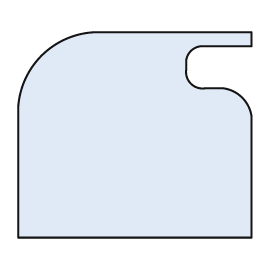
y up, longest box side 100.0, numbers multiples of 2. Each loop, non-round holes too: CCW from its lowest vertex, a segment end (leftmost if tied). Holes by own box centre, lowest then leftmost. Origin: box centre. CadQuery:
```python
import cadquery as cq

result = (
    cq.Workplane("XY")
    .moveTo(-50.0, -44.0)
    .lineTo(50.0, -44.0)
    .lineTo(50.0, 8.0)
    .threePointArc((46.0, 16.0), (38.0, 20.0))
    .lineTo(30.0, 20.0)
    .threePointArc((24.0, 22.0), (22.0, 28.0))
    .lineTo(22.0, 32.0)
    .threePointArc((24.0, 36.0), (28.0, 38.0))
    .lineTo(50.0, 38.0)
    .lineTo(50.0, 44.0)
    .lineTo(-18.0, 44.0)
    .threePointArc((-40.0, 34.0), (-50.0, 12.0))
    .close()
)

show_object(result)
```